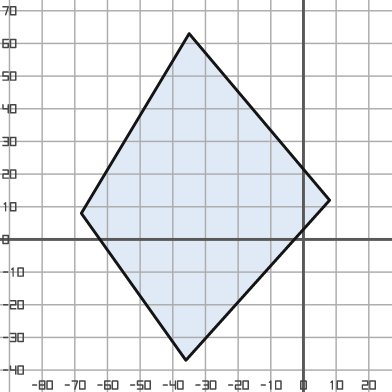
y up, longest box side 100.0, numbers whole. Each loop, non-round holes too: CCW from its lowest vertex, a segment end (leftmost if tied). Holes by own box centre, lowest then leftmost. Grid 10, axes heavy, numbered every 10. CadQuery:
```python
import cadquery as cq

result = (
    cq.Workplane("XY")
    .moveTo(-36.0, -37.0)
    .lineTo(8.0, 12.0)
    .lineTo(-35.0, 63.0)
    .lineTo(-68.0, 8.0)
    .close()
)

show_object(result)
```